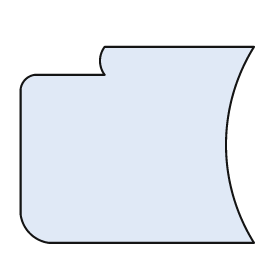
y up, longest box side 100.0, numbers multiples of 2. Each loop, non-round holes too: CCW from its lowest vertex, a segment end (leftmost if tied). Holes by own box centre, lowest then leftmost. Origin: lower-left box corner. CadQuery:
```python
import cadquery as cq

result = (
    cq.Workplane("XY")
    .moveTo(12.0, 0.0)
    .lineTo(100.0, 0.0)
    .threePointArc((88.0, 42.0), (100.0, 84.0))
    .lineTo(36.0, 84.0)
    .threePointArc((34.0, 78.0), (36.0, 72.0))
    .lineTo(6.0, 72.0)
    .threePointArc((2.0, 70.0), (0.0, 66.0))
    .lineTo(0.0, 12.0)
    .threePointArc((4.0, 4.0), (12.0, 0.0))
    .close()
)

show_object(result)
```